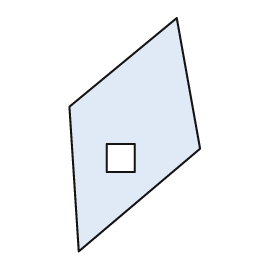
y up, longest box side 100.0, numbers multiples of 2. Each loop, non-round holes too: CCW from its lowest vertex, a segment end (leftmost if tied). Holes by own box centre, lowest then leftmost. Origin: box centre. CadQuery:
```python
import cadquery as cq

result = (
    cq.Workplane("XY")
    .moveTo(-24.0, -50.0)
    .lineTo(28.0, -6.0)
    .lineTo(18.0, 50.0)
    .lineTo(-28.0, 12.0)
    .close()
    .moveTo(-12.0, -16.0)
    .lineTo(0.0, -16.0)
    .lineTo(0.0, -4.0)
    .lineTo(-12.0, -4.0)
    .close()
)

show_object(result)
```